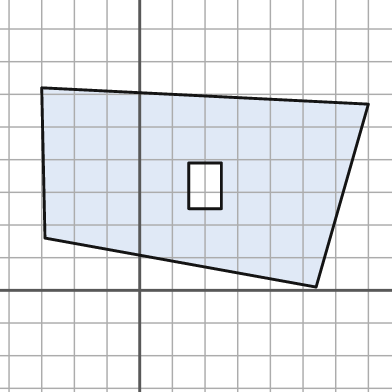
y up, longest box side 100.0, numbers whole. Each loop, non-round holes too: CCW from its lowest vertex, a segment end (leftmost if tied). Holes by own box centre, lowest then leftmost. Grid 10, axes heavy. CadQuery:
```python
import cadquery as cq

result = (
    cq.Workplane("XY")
    .moveTo(54.0, 1.0)
    .lineTo(70.0, 57.0)
    .lineTo(-30.0, 62.0)
    .lineTo(-29.0, 16.0)
    .close()
    .moveTo(15.0, 25.0)
    .lineTo(25.0, 25.0)
    .lineTo(25.0, 39.0)
    .lineTo(15.0, 39.0)
    .close()
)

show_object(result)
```